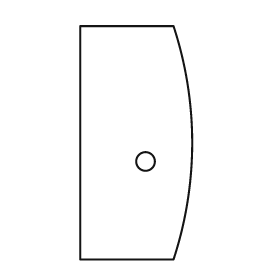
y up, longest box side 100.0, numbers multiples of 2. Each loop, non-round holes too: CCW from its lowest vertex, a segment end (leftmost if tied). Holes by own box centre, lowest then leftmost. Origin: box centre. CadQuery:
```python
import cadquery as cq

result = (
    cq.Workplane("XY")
    .moveTo(-24.0, -50.0)
    .lineTo(16.0, -50.0)
    .threePointArc((24.0, 0.0), (16.0, 50.0))
    .lineTo(-24.0, 50.0)
    .close()
    .moveTo(4.0, -8.0)
    .circle(4.0)
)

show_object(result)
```